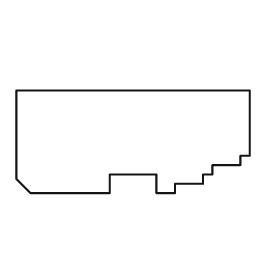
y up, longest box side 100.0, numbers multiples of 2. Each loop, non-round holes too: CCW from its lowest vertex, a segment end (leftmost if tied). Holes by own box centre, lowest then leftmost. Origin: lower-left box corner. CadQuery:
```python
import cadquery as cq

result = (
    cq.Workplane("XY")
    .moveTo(6.0, 0.0)
    .lineTo(40.0, 0.0)
    .lineTo(40.0, 8.0)
    .lineTo(60.0, 8.0)
    .lineTo(60.0, 0.0)
    .lineTo(68.0, 0.0)
    .lineTo(68.0, 4.0)
    .lineTo(80.0, 4.0)
    .lineTo(80.0, 8.0)
    .lineTo(84.0, 8.0)
    .lineTo(84.0, 12.0)
    .lineTo(96.0, 12.0)
    .lineTo(96.0, 16.0)
    .lineTo(100.0, 16.0)
    .lineTo(100.0, 44.0)
    .lineTo(0.0, 44.0)
    .lineTo(0.0, 6.0)
    .close()
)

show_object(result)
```